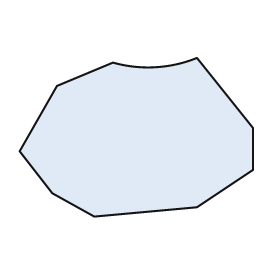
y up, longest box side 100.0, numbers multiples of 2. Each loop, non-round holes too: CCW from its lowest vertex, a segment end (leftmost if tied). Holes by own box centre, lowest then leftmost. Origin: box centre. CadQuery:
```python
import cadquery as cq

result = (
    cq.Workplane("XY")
    .moveTo(-18.0, -34.0)
    .lineTo(26.0, -30.0)
    .lineTo(50.0, -14.0)
    .lineTo(50.0, 4.0)
    .lineTo(26.0, 34.0)
    .threePointArc((8.0, 30.0), (-10.0, 32.0))
    .lineTo(-34.0, 22.0)
    .lineTo(-50.0, -6.0)
    .lineTo(-36.0, -24.0)
    .close()
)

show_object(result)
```